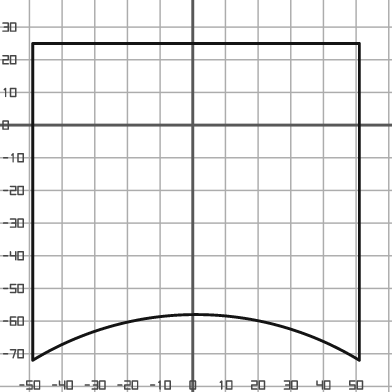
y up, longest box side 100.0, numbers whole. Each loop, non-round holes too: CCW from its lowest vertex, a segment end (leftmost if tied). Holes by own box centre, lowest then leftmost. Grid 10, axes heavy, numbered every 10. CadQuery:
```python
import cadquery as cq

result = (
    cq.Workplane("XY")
    .moveTo(-49.0, -72.0)
    .threePointArc((1.0, -58.0), (51.0, -72.0))
    .lineTo(51.0, 25.0)
    .lineTo(-49.0, 25.0)
    .close()
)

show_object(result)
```